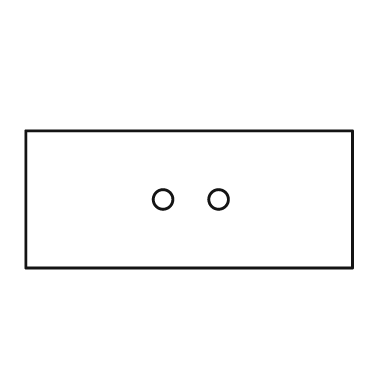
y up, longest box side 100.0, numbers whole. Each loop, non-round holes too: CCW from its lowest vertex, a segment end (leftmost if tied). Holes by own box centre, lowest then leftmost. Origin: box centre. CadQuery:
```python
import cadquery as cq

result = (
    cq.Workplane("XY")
    .moveTo(-50.0, -21.0)
    .lineTo(50.0, -21.0)
    .lineTo(50.0, 21.0)
    .lineTo(-50.0, 21.0)
    .close()
    .moveTo(-8.0, 0.0)
    .circle(3.0)
    .moveTo(9.0, 0.0)
    .circle(3.0)
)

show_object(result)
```